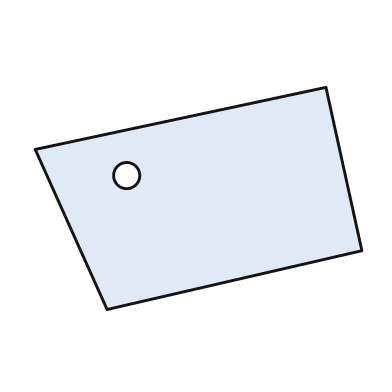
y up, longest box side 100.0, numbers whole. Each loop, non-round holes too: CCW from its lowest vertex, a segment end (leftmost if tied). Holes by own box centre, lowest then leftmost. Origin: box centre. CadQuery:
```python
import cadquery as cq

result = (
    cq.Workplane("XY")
    .moveTo(-28.0, -34.0)
    .lineTo(50.0, -16.0)
    .lineTo(39.0, 34.0)
    .lineTo(-50.0, 15.0)
    .close()
    .moveTo(-22.0, 7.0)
    .circle(4.0)
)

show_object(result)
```